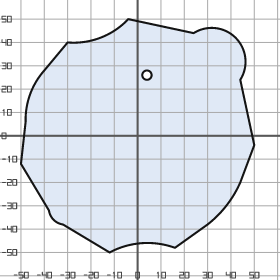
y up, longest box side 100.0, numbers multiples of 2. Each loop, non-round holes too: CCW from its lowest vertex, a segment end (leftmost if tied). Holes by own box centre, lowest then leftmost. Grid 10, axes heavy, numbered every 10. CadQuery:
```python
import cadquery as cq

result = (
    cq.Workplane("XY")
    .moveTo(-12.0, -50.0)
    .threePointArc((2.0, -46.0), (16.0, -48.0))
    .lineTo(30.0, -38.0)
    .threePointArc((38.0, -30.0), (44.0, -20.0))
    .lineTo(50.0, -4.0)
    .lineTo(44.0, 24.0)
    .threePointArc((42.0, 42.0), (24.0, 44.0))
    .lineTo(-4.0, 50.0)
    .threePointArc((-16.0, 42.0), (-30.0, 40.0))
    .lineTo(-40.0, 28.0)
    .threePointArc((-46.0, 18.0), (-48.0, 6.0))
    .lineTo(-50.0, -12.0)
    .lineTo(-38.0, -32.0)
    .threePointArc((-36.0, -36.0), (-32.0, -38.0))
    .close()
    .moveTo(4.0, 26.0)
    .circle(2.0)
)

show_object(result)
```